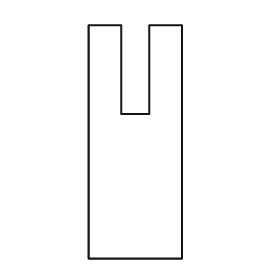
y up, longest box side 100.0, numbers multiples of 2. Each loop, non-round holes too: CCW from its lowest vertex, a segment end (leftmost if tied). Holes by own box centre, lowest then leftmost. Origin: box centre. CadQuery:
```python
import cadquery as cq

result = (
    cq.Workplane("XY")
    .moveTo(-20.0, -50.0)
    .lineTo(20.0, -50.0)
    .lineTo(20.0, 50.0)
    .lineTo(6.0, 50.0)
    .lineTo(6.0, 12.0)
    .lineTo(-6.0, 12.0)
    .lineTo(-6.0, 50.0)
    .lineTo(-20.0, 50.0)
    .close()
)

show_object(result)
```